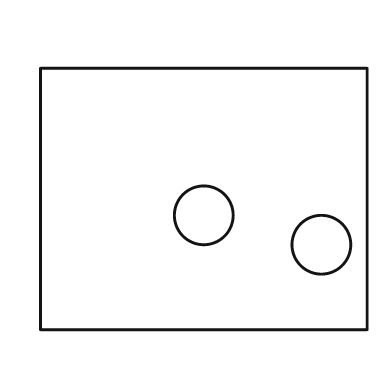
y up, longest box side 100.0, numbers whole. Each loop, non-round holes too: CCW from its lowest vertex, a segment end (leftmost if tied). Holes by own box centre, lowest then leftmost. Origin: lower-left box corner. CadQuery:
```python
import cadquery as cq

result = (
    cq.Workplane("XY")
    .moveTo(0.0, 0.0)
    .lineTo(100.0, 0.0)
    .lineTo(100.0, 80.0)
    .lineTo(0.0, 80.0)
    .close()
    .moveTo(86.0, 26.0)
    .circle(9.0)
    .moveTo(50.0, 35.0)
    .circle(9.0)
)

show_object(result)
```